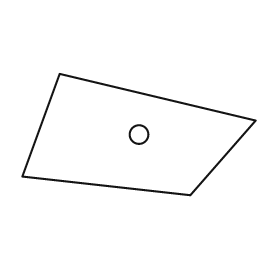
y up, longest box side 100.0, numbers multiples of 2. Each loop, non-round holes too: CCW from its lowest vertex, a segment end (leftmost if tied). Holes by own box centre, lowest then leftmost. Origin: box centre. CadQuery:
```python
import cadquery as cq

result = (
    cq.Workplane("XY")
    .moveTo(22.0, -26.0)
    .lineTo(50.0, 6.0)
    .lineTo(-34.0, 26.0)
    .lineTo(-50.0, -18.0)
    .close()
    .moveTo(0.0, 0.0)
    .circle(4.0)
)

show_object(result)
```